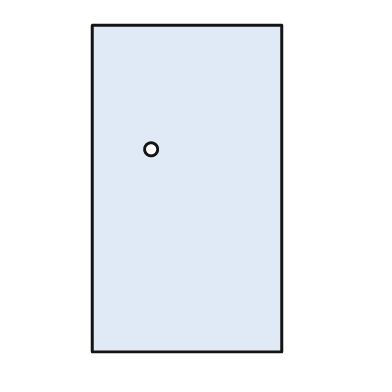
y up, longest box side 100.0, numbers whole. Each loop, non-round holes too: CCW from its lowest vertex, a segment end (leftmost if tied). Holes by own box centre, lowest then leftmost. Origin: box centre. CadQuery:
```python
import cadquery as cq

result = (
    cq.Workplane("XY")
    .moveTo(-29.0, -50.0)
    .lineTo(29.0, -50.0)
    .lineTo(29.0, 50.0)
    .lineTo(-29.0, 50.0)
    .close()
    .moveTo(-11.0, 12.0)
    .circle(2.0)
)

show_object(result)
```